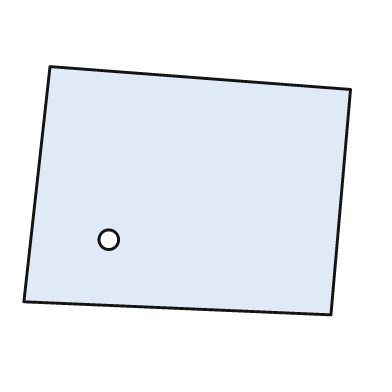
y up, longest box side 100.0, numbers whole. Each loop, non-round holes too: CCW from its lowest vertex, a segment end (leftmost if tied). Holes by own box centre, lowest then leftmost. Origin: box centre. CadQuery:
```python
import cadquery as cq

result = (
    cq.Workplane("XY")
    .moveTo(44.0, -38.0)
    .lineTo(50.0, 31.0)
    .lineTo(-42.0, 38.0)
    .lineTo(-50.0, -34.0)
    .close()
    .moveTo(-24.0, -15.0)
    .circle(3.0)
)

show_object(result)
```